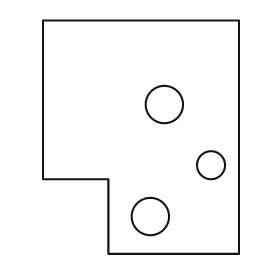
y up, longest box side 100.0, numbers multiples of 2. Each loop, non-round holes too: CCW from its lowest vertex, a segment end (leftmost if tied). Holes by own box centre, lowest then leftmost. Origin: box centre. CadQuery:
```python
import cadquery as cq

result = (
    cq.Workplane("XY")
    .moveTo(-14.0, -50.0)
    .lineTo(42.0, -50.0)
    .lineTo(42.0, 50.0)
    .lineTo(-42.0, 50.0)
    .lineTo(-42.0, -18.0)
    .lineTo(-14.0, -18.0)
    .close()
    .moveTo(4.0, -34.0)
    .circle(8.0)
    .moveTo(30.0, -12.0)
    .circle(6.0)
    .moveTo(10.0, 14.0)
    .circle(8.0)
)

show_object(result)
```